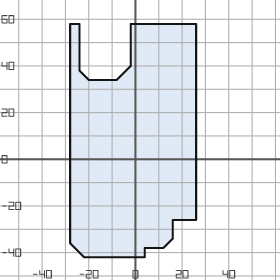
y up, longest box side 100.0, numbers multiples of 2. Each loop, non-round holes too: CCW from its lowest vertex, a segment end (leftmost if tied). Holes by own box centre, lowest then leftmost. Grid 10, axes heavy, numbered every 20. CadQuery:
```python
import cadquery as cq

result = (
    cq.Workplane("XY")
    .moveTo(-22.0, -42.0)
    .lineTo(4.0, -42.0)
    .lineTo(4.0, -38.0)
    .lineTo(12.0, -38.0)
    .lineTo(16.0, -34.0)
    .lineTo(16.0, -26.0)
    .lineTo(26.0, -26.0)
    .lineTo(26.0, 58.0)
    .lineTo(-2.0, 58.0)
    .lineTo(-2.0, 40.0)
    .lineTo(-8.0, 34.0)
    .lineTo(-20.0, 34.0)
    .lineTo(-24.0, 38.0)
    .lineTo(-24.0, 58.0)
    .lineTo(-28.0, 58.0)
    .lineTo(-28.0, -36.0)
    .close()
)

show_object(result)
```